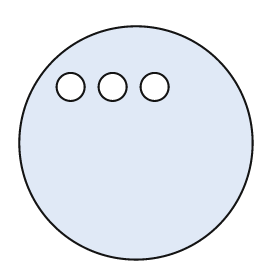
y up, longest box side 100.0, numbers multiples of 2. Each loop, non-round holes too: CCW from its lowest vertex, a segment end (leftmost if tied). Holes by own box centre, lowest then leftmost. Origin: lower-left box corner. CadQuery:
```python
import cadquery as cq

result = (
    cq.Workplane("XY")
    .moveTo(50.0, 50.0)
    .circle(50.0)
    .moveTo(22.0, 74.0)
    .circle(6.0)
    .moveTo(40.0, 74.0)
    .circle(6.0)
    .moveTo(58.0, 74.0)
    .circle(6.0)
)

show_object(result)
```